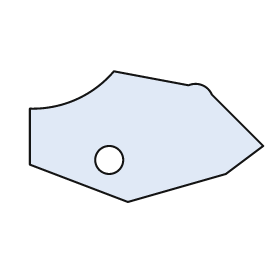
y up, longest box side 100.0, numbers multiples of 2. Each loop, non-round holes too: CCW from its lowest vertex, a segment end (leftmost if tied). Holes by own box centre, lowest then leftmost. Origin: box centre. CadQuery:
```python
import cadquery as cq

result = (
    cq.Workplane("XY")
    .moveTo(-8.0, -28.0)
    .lineTo(34.0, -16.0)
    .lineTo(50.0, -4.0)
    .lineTo(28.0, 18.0)
    .threePointArc((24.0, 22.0), (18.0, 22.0))
    .lineTo(-14.0, 28.0)
    .threePointArc((-30.0, 16.0), (-50.0, 12.0))
    .lineTo(-50.0, -12.0)
    .close()
    .moveTo(-16.0, -10.0)
    .circle(6.0)
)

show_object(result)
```